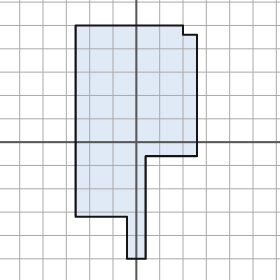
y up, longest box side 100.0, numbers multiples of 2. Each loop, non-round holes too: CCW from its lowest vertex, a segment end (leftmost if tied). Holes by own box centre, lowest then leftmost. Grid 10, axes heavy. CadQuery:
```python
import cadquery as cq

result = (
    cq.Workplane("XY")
    .moveTo(-4.0, -50.0)
    .lineTo(4.0, -50.0)
    .lineTo(4.0, -6.0)
    .lineTo(26.0, -6.0)
    .lineTo(26.0, 46.0)
    .lineTo(20.0, 46.0)
    .lineTo(20.0, 50.0)
    .lineTo(-26.0, 50.0)
    .lineTo(-26.0, -32.0)
    .lineTo(-4.0, -32.0)
    .close()
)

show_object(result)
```